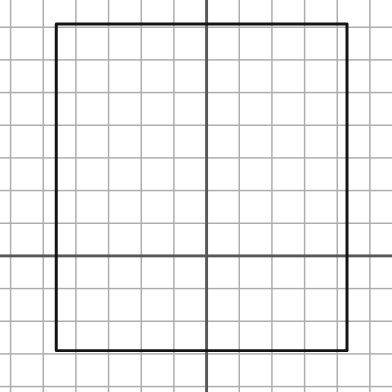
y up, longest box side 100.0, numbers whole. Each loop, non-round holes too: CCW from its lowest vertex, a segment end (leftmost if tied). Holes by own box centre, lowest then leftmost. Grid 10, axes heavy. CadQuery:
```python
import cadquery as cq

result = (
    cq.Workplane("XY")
    .moveTo(-46.0, -29.0)
    .lineTo(43.0, -29.0)
    .lineTo(43.0, 71.0)
    .lineTo(-46.0, 71.0)
    .close()
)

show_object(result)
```